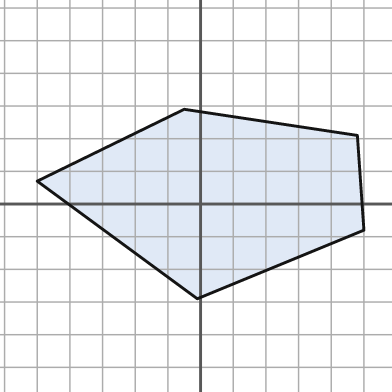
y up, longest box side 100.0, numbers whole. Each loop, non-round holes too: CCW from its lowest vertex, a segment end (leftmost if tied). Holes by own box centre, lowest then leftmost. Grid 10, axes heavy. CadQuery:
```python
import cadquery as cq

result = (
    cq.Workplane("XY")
    .moveTo(-1.0, -29.0)
    .lineTo(50.0, -8.0)
    .lineTo(48.0, 21.0)
    .lineTo(-5.0, 29.0)
    .lineTo(-50.0, 7.0)
    .close()
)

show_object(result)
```